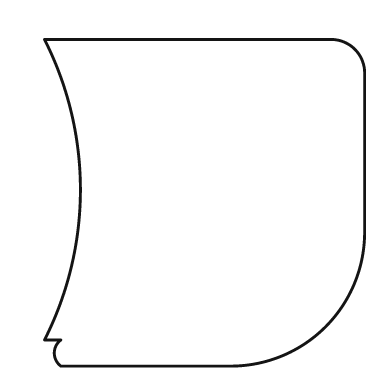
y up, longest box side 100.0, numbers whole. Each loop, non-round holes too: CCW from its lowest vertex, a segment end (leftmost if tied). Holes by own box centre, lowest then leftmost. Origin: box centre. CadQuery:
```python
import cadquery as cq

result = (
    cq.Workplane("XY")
    .moveTo(-44.0, -50.0)
    .lineTo(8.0, -50.0)
    .threePointArc((37.0, -38.0), (49.0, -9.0))
    .lineTo(49.0, 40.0)
    .threePointArc((46.0, 47.0), (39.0, 50.0))
    .lineTo(-49.0, 50.0)
    .threePointArc((-38.0, 4.0), (-49.0, -42.0))
    .lineTo(-44.0, -42.0)
    .threePointArc((-46.0, -46.0), (-44.0, -50.0))
    .close()
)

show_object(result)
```